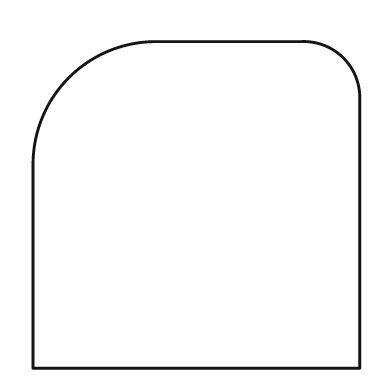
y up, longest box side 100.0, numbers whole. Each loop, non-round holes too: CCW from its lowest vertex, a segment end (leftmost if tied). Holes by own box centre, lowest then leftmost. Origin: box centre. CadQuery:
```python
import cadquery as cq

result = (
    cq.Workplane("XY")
    .moveTo(-50.0, -50.0)
    .lineTo(50.0, -50.0)
    .lineTo(50.0, 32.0)
    .threePointArc((45.0, 45.0), (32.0, 50.0))
    .lineTo(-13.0, 50.0)
    .threePointArc((-39.0, 39.0), (-50.0, 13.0))
    .close()
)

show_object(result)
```